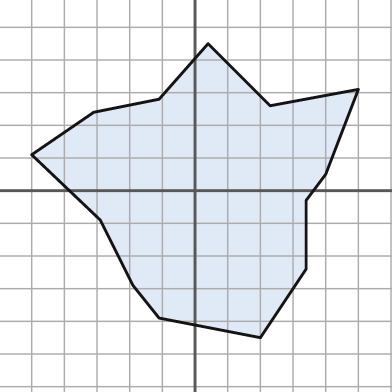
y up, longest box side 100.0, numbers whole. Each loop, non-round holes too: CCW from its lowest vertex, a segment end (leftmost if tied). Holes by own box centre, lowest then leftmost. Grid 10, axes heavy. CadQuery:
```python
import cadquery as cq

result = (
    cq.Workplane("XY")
    .moveTo(20.0, -45.0)
    .lineTo(34.0, -24.0)
    .lineTo(34.0, -3.0)
    .lineTo(40.0, 5.0)
    .lineTo(50.0, 31.0)
    .lineTo(23.0, 26.0)
    .lineTo(4.0, 45.0)
    .lineTo(-11.0, 28.0)
    .lineTo(-31.0, 24.0)
    .lineTo(-50.0, 11.0)
    .lineTo(-29.0, -9.0)
    .lineTo(-19.0, -29.0)
    .lineTo(-11.0, -39.0)
    .close()
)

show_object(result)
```